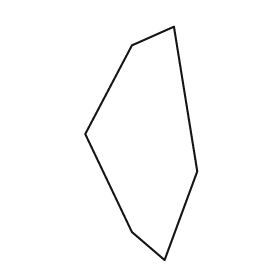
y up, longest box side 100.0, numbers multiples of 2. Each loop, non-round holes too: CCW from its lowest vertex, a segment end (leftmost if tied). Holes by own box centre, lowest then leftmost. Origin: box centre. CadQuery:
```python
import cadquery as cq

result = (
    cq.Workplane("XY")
    .moveTo(10.0, -50.0)
    .lineTo(24.0, -12.0)
    .lineTo(14.0, 50.0)
    .lineTo(-4.0, 42.0)
    .lineTo(-24.0, 4.0)
    .lineTo(-4.0, -38.0)
    .close()
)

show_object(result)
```